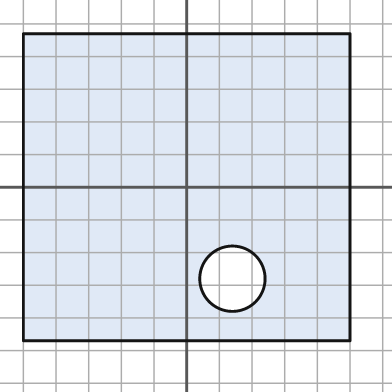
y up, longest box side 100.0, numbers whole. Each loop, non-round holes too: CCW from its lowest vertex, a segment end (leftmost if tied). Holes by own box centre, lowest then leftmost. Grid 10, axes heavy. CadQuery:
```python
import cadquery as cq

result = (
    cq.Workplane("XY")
    .moveTo(-50.0, -47.0)
    .lineTo(50.0, -47.0)
    .lineTo(50.0, 47.0)
    .lineTo(-50.0, 47.0)
    .close()
    .moveTo(14.0, -28.0)
    .circle(10.0)
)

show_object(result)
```